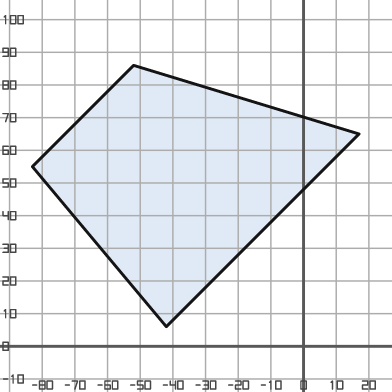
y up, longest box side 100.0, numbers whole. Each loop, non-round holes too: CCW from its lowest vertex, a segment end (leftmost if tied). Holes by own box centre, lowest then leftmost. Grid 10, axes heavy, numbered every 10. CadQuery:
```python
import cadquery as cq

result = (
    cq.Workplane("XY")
    .moveTo(-42.0, 6.0)
    .lineTo(17.0, 65.0)
    .lineTo(-52.0, 86.0)
    .lineTo(-83.0, 55.0)
    .close()
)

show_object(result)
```